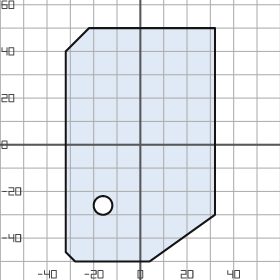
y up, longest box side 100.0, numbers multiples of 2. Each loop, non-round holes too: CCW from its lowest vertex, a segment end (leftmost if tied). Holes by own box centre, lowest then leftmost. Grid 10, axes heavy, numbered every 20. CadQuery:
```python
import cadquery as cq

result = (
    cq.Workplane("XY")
    .moveTo(-28.0, -50.0)
    .lineTo(4.0, -50.0)
    .lineTo(32.0, -30.0)
    .lineTo(32.0, 50.0)
    .lineTo(-22.0, 50.0)
    .lineTo(-32.0, 40.0)
    .lineTo(-32.0, -46.0)
    .close()
    .moveTo(-16.0, -26.0)
    .circle(4.0)
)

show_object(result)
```